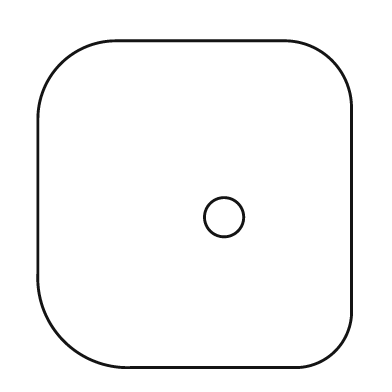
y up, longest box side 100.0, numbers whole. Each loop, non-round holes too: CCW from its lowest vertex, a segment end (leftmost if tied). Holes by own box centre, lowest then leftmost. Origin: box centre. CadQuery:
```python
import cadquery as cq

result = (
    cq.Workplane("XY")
    .moveTo(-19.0, -50.0)
    .lineTo(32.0, -50.0)
    .threePointArc((43.0, -45.0), (48.0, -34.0))
    .lineTo(48.0, 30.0)
    .threePointArc((42.0, 44.0), (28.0, 50.0))
    .lineTo(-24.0, 50.0)
    .threePointArc((-41.0, 43.0), (-48.0, 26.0))
    .lineTo(-48.0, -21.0)
    .threePointArc((-40.0, -42.0), (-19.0, -50.0))
    .close()
    .moveTo(9.0, -4.0)
    .circle(6.0)
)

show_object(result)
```